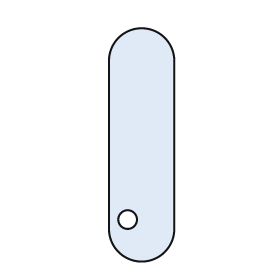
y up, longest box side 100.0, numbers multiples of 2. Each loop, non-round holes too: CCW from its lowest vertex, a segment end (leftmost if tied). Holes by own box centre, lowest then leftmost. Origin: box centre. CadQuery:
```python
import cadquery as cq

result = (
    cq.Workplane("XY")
    .moveTo(-14.0, -36.0)
    .threePointArc((0.0, -50.0), (14.0, -36.0))
    .lineTo(14.0, 36.0)
    .threePointArc((0.0, 50.0), (-14.0, 36.0))
    .close()
    .moveTo(-6.0, -32.0)
    .circle(4.0)
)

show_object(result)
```